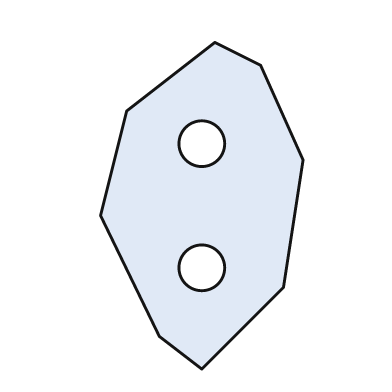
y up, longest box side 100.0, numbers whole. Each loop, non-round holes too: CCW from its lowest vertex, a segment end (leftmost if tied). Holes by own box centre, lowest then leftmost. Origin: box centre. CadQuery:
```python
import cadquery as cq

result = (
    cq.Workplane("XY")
    .moveTo(0.0, -50.0)
    .lineTo(25.0, -25.0)
    .lineTo(31.0, 14.0)
    .lineTo(18.0, 43.0)
    .lineTo(4.0, 50.0)
    .lineTo(-23.0, 29.0)
    .lineTo(-31.0, -3.0)
    .lineTo(-13.0, -40.0)
    .close()
    .moveTo(0.0, -19.0)
    .circle(7.0)
    .moveTo(0.0, 19.0)
    .circle(7.0)
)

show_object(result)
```